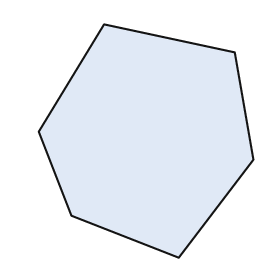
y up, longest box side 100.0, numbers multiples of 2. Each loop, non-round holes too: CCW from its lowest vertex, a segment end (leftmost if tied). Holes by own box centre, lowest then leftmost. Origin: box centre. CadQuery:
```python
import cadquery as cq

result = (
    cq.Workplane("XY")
    .moveTo(14.0, -50.0)
    .lineTo(46.0, -8.0)
    .lineTo(38.0, 38.0)
    .lineTo(-18.0, 50.0)
    .lineTo(-46.0, 4.0)
    .lineTo(-32.0, -32.0)
    .close()
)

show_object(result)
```